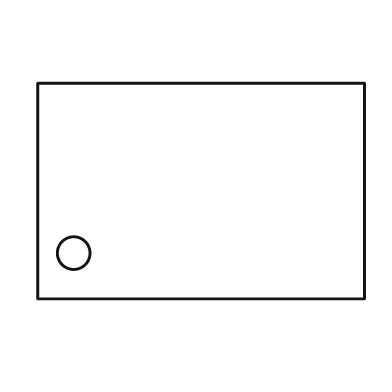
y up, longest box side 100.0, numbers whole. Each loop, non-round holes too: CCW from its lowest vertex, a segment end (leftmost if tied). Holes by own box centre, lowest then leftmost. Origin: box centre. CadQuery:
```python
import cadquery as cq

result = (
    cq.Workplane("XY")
    .moveTo(-50.0, -33.0)
    .lineTo(50.0, -33.0)
    .lineTo(50.0, 33.0)
    .lineTo(-50.0, 33.0)
    .close()
    .moveTo(-39.0, -19.0)
    .circle(5.0)
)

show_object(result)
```